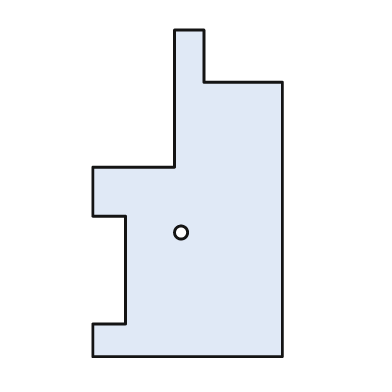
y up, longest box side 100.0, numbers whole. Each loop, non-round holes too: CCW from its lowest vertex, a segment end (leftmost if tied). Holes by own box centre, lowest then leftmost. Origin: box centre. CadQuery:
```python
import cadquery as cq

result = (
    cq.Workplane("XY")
    .moveTo(-29.0, -50.0)
    .lineTo(29.0, -50.0)
    .lineTo(29.0, 34.0)
    .lineTo(5.0, 34.0)
    .lineTo(5.0, 50.0)
    .lineTo(-4.0, 50.0)
    .lineTo(-4.0, 8.0)
    .lineTo(-29.0, 8.0)
    .lineTo(-29.0, -7.0)
    .lineTo(-19.0, -7.0)
    .lineTo(-19.0, -40.0)
    .lineTo(-29.0, -40.0)
    .close()
    .moveTo(-2.0, -12.0)
    .circle(2.0)
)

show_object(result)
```